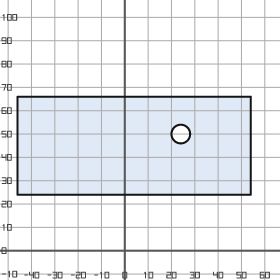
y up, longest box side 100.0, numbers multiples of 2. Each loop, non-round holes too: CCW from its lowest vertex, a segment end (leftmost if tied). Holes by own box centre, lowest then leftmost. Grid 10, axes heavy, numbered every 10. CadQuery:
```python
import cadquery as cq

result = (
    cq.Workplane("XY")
    .moveTo(-46.0, 24.0)
    .lineTo(54.0, 24.0)
    .lineTo(54.0, 66.0)
    .lineTo(-46.0, 66.0)
    .close()
    .moveTo(24.0, 50.0)
    .circle(4.0)
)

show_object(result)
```